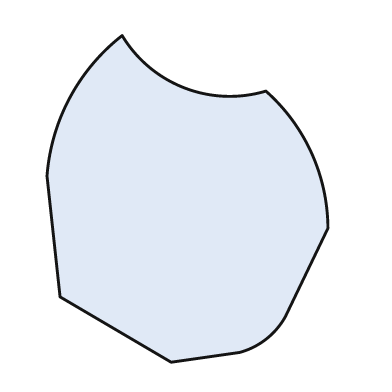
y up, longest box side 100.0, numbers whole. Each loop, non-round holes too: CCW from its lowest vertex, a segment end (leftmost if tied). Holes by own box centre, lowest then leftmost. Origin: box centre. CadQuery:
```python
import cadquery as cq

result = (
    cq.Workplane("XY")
    .moveTo(-5.0, -50.0)
    .lineTo(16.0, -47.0)
    .threePointArc((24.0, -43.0), (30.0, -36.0))
    .lineTo(43.0, -9.0)
    .threePointArc((38.0, 14.0), (24.0, 33.0))
    .threePointArc((-1.0, 34.0), (-20.0, 50.0))
    .threePointArc((-36.0, 31.0), (-43.0, 7.0))
    .lineTo(-39.0, -30.0)
    .close()
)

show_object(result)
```